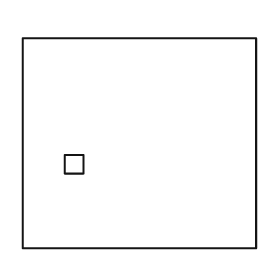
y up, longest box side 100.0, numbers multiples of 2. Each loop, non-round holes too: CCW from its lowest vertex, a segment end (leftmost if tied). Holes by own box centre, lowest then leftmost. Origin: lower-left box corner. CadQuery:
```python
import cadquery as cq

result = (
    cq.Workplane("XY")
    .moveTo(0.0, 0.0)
    .lineTo(100.0, 0.0)
    .lineTo(100.0, 90.0)
    .lineTo(0.0, 90.0)
    .close()
    .moveTo(18.0, 32.0)
    .lineTo(26.0, 32.0)
    .lineTo(26.0, 40.0)
    .lineTo(18.0, 40.0)
    .close()
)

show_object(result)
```